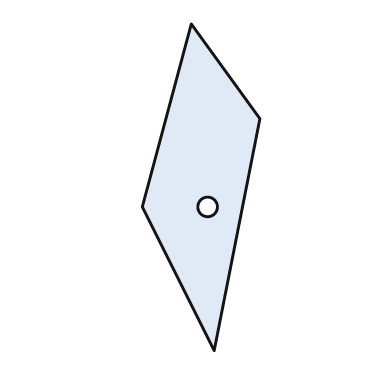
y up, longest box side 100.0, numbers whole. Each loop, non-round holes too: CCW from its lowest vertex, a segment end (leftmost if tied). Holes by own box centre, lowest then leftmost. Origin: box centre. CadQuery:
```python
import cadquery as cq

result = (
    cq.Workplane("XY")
    .moveTo(4.0, -50.0)
    .lineTo(18.0, 21.0)
    .lineTo(-3.0, 50.0)
    .lineTo(-18.0, -6.0)
    .close()
    .moveTo(2.0, -6.0)
    .circle(3.0)
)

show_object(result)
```